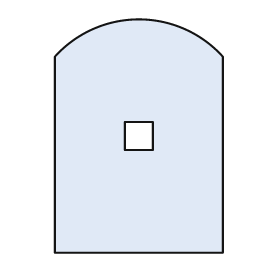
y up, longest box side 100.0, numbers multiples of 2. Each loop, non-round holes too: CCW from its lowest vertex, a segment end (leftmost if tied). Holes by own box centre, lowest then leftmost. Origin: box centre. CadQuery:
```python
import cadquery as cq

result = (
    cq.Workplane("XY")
    .moveTo(-36.0, -50.0)
    .lineTo(36.0, -50.0)
    .lineTo(36.0, 34.0)
    .threePointArc((0.0, 50.0), (-36.0, 34.0))
    .close()
    .moveTo(-6.0, -6.0)
    .lineTo(6.0, -6.0)
    .lineTo(6.0, 6.0)
    .lineTo(-6.0, 6.0)
    .close()
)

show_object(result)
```